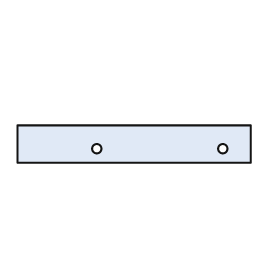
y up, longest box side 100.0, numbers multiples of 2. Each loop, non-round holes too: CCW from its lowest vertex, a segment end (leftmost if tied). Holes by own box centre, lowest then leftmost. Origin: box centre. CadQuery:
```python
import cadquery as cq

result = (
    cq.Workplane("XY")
    .moveTo(-50.0, -8.0)
    .lineTo(50.0, -8.0)
    .lineTo(50.0, 8.0)
    .lineTo(-50.0, 8.0)
    .close()
    .moveTo(-16.0, -2.0)
    .circle(2.0)
    .moveTo(38.0, -2.0)
    .circle(2.0)
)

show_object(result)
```